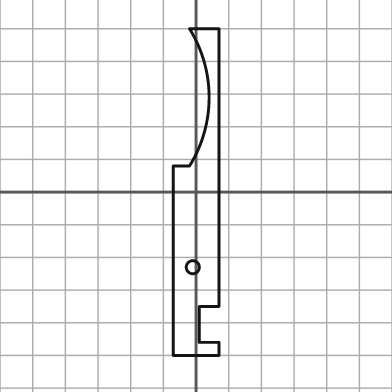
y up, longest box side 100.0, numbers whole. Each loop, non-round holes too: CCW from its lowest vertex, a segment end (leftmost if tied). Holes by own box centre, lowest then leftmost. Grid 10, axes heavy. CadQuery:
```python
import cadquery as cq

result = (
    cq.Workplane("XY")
    .moveTo(-7.0, -50.0)
    .lineTo(7.0, -50.0)
    .lineTo(7.0, -46.0)
    .lineTo(1.0, -46.0)
    .lineTo(1.0, -35.0)
    .lineTo(7.0, -35.0)
    .lineTo(7.0, 50.0)
    .lineTo(-2.0, 50.0)
    .threePointArc((4.0, 29.0), (-2.0, 8.0))
    .lineTo(-7.0, 8.0)
    .close()
    .moveTo(-1.0, -23.0)
    .circle(2.0)
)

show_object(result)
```